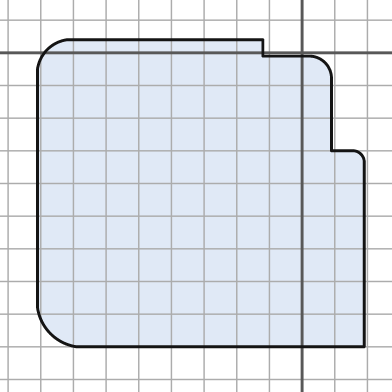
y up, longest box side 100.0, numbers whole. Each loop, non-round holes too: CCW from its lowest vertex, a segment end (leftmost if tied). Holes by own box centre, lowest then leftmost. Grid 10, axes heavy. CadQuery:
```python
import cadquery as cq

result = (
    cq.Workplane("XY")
    .moveTo(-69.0, -90.0)
    .lineTo(19.0, -90.0)
    .lineTo(19.0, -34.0)
    .threePointArc((18.0, -31.0), (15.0, -30.0))
    .lineTo(9.0, -30.0)
    .lineTo(9.0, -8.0)
    .threePointArc((7.0, -3.0), (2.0, -1.0))
    .lineTo(-12.0, -1.0)
    .lineTo(-12.0, 4.0)
    .lineTo(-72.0, 4.0)
    .threePointArc((-78.0, 1.0), (-81.0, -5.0))
    .lineTo(-81.0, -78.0)
    .threePointArc((-77.0, -86.0), (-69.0, -90.0))
    .close()
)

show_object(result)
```